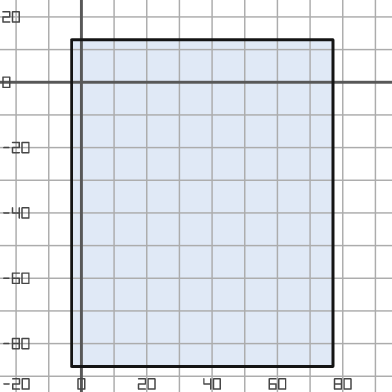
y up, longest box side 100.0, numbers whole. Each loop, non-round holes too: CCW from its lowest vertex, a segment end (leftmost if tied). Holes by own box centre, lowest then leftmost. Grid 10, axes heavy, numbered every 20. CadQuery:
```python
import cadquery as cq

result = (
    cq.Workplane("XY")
    .moveTo(-3.0, -87.0)
    .lineTo(77.0, -87.0)
    .lineTo(77.0, 13.0)
    .lineTo(-3.0, 13.0)
    .close()
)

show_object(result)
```